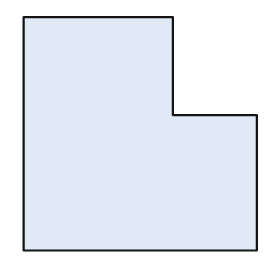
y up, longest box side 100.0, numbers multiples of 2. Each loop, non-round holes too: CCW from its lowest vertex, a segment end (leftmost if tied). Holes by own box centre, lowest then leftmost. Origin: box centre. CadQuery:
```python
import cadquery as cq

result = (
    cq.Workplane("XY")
    .moveTo(-50.0, -50.0)
    .lineTo(50.0, -50.0)
    .lineTo(50.0, 8.0)
    .lineTo(14.0, 8.0)
    .lineTo(14.0, 50.0)
    .lineTo(-50.0, 50.0)
    .close()
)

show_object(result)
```